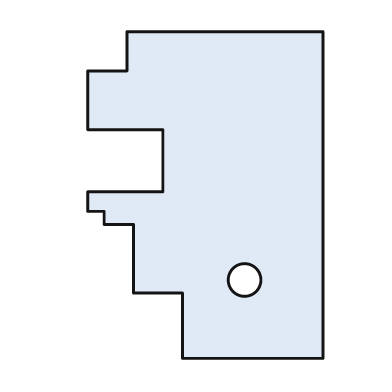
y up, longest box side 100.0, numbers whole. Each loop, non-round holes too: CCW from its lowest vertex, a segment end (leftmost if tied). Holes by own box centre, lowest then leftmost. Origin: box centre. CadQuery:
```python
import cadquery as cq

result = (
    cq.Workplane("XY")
    .moveTo(-7.0, -50.0)
    .lineTo(36.0, -50.0)
    .lineTo(36.0, 50.0)
    .lineTo(-24.0, 50.0)
    .lineTo(-24.0, 38.0)
    .lineTo(-36.0, 38.0)
    .lineTo(-36.0, 20.0)
    .lineTo(-13.0, 20.0)
    .lineTo(-13.0, 1.0)
    .lineTo(-36.0, 1.0)
    .lineTo(-36.0, -5.0)
    .lineTo(-31.0, -5.0)
    .lineTo(-31.0, -9.0)
    .lineTo(-22.0, -9.0)
    .lineTo(-22.0, -30.0)
    .lineTo(-7.0, -30.0)
    .close()
    .moveTo(12.0, -26.0)
    .circle(5.0)
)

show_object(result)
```